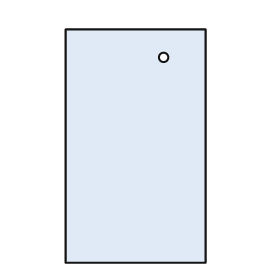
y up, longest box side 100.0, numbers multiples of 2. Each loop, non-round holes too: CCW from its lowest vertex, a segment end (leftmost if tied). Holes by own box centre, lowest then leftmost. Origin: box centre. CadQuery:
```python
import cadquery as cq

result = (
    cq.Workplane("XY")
    .moveTo(-30.0, -50.0)
    .lineTo(30.0, -50.0)
    .lineTo(30.0, 50.0)
    .lineTo(-30.0, 50.0)
    .close()
    .moveTo(12.0, 38.0)
    .circle(2.0)
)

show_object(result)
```